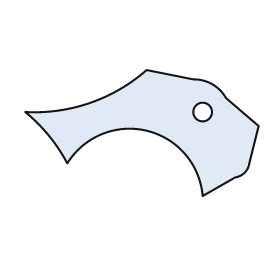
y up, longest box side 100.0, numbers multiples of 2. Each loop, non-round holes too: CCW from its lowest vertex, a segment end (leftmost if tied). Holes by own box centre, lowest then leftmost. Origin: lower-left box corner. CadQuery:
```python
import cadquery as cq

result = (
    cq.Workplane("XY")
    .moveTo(76.0, 0.0)
    .lineTo(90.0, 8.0)
    .threePointArc((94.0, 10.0), (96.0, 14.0))
    .lineTo(100.0, 30.0)
    .lineTo(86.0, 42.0)
    .threePointArc((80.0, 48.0), (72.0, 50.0))
    .lineTo(52.0, 54.0)
    .threePointArc((28.0, 40.0), (0.0, 36.0))
    .threePointArc((10.0, 26.0), (18.0, 14.0))
    .threePointArc((52.0, 28.0), (76.0, 0.0))
    .close()
    .moveTo(76.0, 36.0)
    .circle(4.0)
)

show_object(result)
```